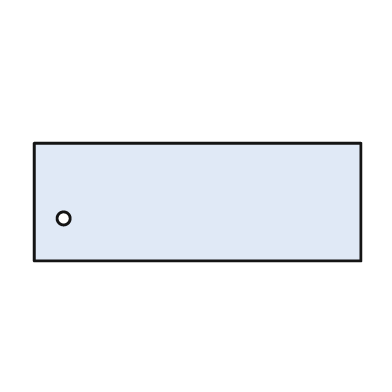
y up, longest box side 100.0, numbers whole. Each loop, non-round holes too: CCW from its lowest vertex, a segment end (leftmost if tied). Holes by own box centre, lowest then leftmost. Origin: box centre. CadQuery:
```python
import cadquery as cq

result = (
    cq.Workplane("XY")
    .moveTo(-50.0, -18.0)
    .lineTo(50.0, -18.0)
    .lineTo(50.0, 18.0)
    .lineTo(-50.0, 18.0)
    .close()
    .moveTo(-41.0, -5.0)
    .circle(2.0)
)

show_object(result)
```